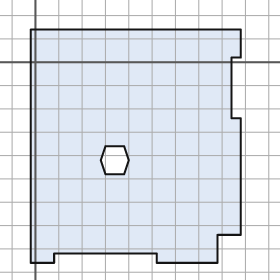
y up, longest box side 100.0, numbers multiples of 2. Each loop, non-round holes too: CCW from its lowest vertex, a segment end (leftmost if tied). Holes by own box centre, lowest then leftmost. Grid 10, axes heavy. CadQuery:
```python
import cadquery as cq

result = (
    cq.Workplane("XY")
    .moveTo(-2.0, -86.0)
    .lineTo(8.0, -86.0)
    .lineTo(8.0, -82.0)
    .lineTo(52.0, -82.0)
    .lineTo(52.0, -86.0)
    .lineTo(78.0, -86.0)
    .lineTo(78.0, -74.0)
    .lineTo(88.0, -74.0)
    .lineTo(88.0, -24.0)
    .lineTo(84.0, -24.0)
    .lineTo(84.0, 2.0)
    .lineTo(88.0, 2.0)
    .lineTo(88.0, 14.0)
    .lineTo(-2.0, 14.0)
    .close()
    .moveTo(30.0, -48.0)
    .lineTo(38.0, -48.0)
    .lineTo(40.0, -42.0)
    .lineTo(38.0, -36.0)
    .lineTo(30.0, -36.0)
    .lineTo(28.0, -42.0)
    .close()
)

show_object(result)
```